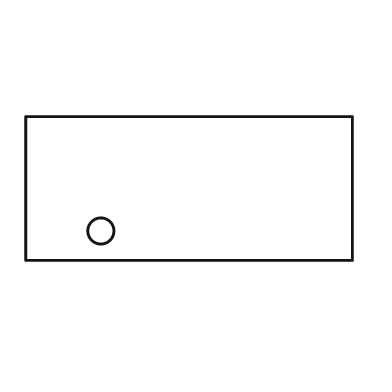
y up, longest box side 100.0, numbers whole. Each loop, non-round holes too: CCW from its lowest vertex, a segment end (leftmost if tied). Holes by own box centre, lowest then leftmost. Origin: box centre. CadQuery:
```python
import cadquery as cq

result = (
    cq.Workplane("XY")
    .moveTo(-50.0, -22.0)
    .lineTo(50.0, -22.0)
    .lineTo(50.0, 22.0)
    .lineTo(-50.0, 22.0)
    .close()
    .moveTo(-27.0, -13.0)
    .circle(4.0)
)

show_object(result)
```